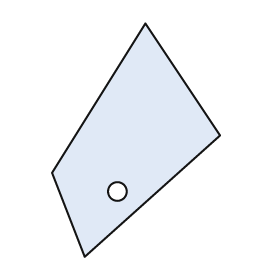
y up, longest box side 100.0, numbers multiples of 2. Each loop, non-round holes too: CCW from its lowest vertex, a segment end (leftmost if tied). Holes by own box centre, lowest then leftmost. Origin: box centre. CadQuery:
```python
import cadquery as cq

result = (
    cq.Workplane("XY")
    .moveTo(-22.0, -50.0)
    .lineTo(36.0, 2.0)
    .lineTo(4.0, 50.0)
    .lineTo(-36.0, -14.0)
    .close()
    .moveTo(-8.0, -22.0)
    .circle(4.0)
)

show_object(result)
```